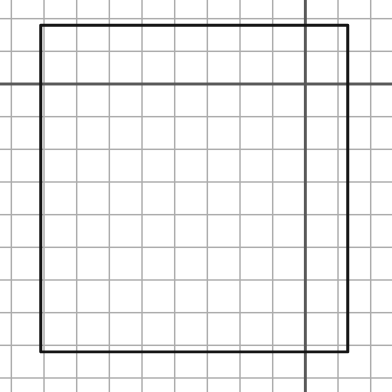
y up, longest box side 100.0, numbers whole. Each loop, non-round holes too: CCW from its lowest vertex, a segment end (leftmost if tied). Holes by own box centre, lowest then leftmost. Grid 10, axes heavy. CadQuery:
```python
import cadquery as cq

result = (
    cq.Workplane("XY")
    .moveTo(-81.0, -82.0)
    .lineTo(13.0, -82.0)
    .lineTo(13.0, 18.0)
    .lineTo(-81.0, 18.0)
    .close()
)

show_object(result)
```